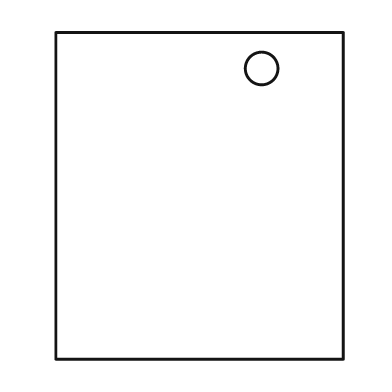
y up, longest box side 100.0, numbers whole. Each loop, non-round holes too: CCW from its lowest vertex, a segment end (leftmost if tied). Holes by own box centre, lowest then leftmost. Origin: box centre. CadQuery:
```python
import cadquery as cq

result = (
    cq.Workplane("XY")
    .moveTo(-44.0, -50.0)
    .lineTo(44.0, -50.0)
    .lineTo(44.0, 50.0)
    .lineTo(-44.0, 50.0)
    .close()
    .moveTo(19.0, 39.0)
    .circle(5.0)
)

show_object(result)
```